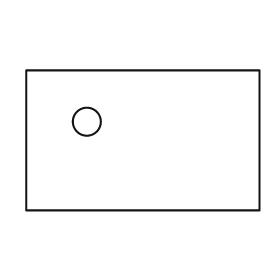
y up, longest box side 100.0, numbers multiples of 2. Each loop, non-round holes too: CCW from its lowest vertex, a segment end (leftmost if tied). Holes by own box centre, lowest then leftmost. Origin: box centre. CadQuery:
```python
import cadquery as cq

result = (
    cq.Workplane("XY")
    .moveTo(-50.0, -30.0)
    .lineTo(50.0, -30.0)
    .lineTo(50.0, 30.0)
    .lineTo(-50.0, 30.0)
    .close()
    .moveTo(-24.0, 8.0)
    .circle(6.0)
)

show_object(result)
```